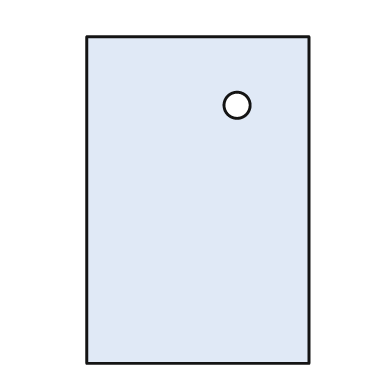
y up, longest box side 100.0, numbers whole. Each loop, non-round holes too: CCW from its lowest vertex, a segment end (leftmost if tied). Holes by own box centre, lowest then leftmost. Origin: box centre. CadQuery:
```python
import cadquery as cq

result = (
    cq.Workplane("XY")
    .moveTo(-34.0, -50.0)
    .lineTo(34.0, -50.0)
    .lineTo(34.0, 50.0)
    .lineTo(-34.0, 50.0)
    .close()
    .moveTo(12.0, 29.0)
    .circle(4.0)
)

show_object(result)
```